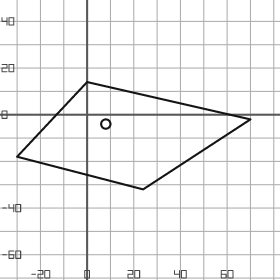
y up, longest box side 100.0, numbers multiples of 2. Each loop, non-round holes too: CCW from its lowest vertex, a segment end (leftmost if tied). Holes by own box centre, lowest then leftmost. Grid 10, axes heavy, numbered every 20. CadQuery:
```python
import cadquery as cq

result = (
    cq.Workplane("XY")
    .moveTo(24.0, -32.0)
    .lineTo(70.0, -2.0)
    .lineTo(0.0, 14.0)
    .lineTo(-30.0, -18.0)
    .close()
    .moveTo(8.0, -4.0)
    .circle(2.0)
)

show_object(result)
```